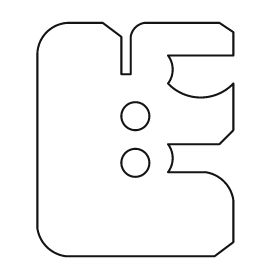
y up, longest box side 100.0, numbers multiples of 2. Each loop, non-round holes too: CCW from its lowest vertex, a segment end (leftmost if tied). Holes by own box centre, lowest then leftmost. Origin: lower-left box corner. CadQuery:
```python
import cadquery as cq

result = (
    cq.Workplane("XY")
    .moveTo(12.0, 0.0)
    .lineTo(76.0, 0.0)
    .lineTo(84.0, 6.0)
    .lineTo(84.0, 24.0)
    .threePointArc((80.0, 32.0), (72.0, 36.0))
    .lineTo(56.0, 36.0)
    .threePointArc((58.0, 42.0), (56.0, 48.0))
    .lineTo(78.0, 48.0)
    .lineTo(84.0, 54.0)
    .lineTo(84.0, 74.0)
    .threePointArc((70.0, 68.0), (56.0, 74.0))
    .threePointArc((58.0, 80.0), (56.0, 86.0))
    .lineTo(84.0, 86.0)
    .lineTo(84.0, 96.0)
    .lineTo(78.0, 100.0)
    .lineTo(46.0, 100.0)
    .threePointArc((42.0, 98.0), (40.0, 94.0))
    .lineTo(40.0, 78.0)
    .lineTo(36.0, 78.0)
    .lineTo(36.0, 94.0)
    .lineTo(28.0, 100.0)
    .lineTo(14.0, 100.0)
    .threePointArc((4.0, 96.0), (0.0, 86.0))
    .lineTo(0.0, 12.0)
    .threePointArc((4.0, 4.0), (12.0, 0.0))
    .close()
    .moveTo(42.0, 40.0)
    .circle(6.0)
    .moveTo(42.0, 60.0)
    .circle(6.0)
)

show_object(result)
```